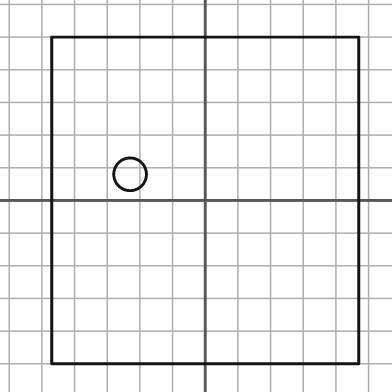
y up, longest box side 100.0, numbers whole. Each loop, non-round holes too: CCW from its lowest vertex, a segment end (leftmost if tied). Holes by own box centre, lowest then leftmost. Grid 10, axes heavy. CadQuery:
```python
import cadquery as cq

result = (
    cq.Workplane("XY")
    .moveTo(-47.0, -50.0)
    .lineTo(47.0, -50.0)
    .lineTo(47.0, 50.0)
    .lineTo(-47.0, 50.0)
    .close()
    .moveTo(-23.0, 8.0)
    .circle(5.0)
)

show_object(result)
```